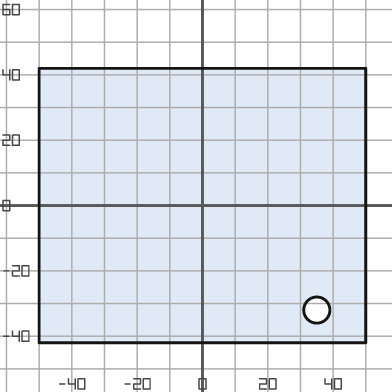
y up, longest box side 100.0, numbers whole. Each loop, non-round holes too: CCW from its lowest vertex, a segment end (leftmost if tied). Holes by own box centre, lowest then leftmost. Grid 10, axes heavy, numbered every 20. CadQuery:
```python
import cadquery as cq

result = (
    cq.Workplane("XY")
    .moveTo(-50.0, -42.0)
    .lineTo(50.0, -42.0)
    .lineTo(50.0, 42.0)
    .lineTo(-50.0, 42.0)
    .close()
    .moveTo(35.0, -32.0)
    .circle(4.0)
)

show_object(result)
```